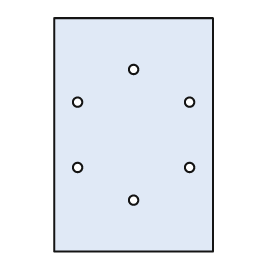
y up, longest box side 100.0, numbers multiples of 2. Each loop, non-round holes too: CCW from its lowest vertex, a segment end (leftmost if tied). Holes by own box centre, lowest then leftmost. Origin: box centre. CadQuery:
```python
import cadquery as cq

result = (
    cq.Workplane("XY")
    .moveTo(-34.0, -50.0)
    .lineTo(34.0, -50.0)
    .lineTo(34.0, 50.0)
    .lineTo(-34.0, 50.0)
    .close()
    .moveTo(0.0, -28.0)
    .circle(2.0)
    .moveTo(-24.0, -14.0)
    .circle(2.0)
    .moveTo(24.0, -14.0)
    .circle(2.0)
    .moveTo(-24.0, 14.0)
    .circle(2.0)
    .moveTo(24.0, 14.0)
    .circle(2.0)
    .moveTo(0.0, 28.0)
    .circle(2.0)
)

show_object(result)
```